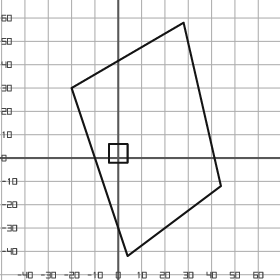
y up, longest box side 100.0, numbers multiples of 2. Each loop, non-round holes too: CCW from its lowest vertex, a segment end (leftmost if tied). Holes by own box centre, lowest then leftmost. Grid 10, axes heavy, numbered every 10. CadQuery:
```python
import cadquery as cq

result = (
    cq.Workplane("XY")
    .moveTo(4.0, -42.0)
    .lineTo(44.0, -12.0)
    .lineTo(28.0, 58.0)
    .lineTo(-20.0, 30.0)
    .close()
    .moveTo(-4.0, -2.0)
    .lineTo(4.0, -2.0)
    .lineTo(4.0, 6.0)
    .lineTo(-4.0, 6.0)
    .close()
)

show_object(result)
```